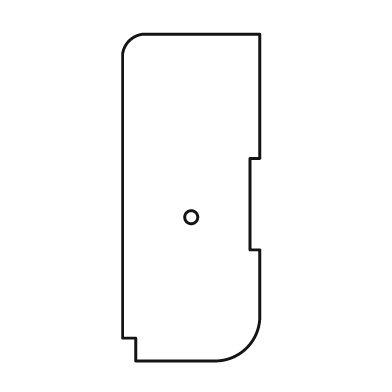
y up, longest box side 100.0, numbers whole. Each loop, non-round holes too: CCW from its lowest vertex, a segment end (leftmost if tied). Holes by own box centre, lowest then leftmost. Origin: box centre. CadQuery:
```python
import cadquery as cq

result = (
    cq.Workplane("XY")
    .moveTo(-17.0, -50.0)
    .lineTo(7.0, -50.0)
    .threePointArc((17.0, -46.0), (21.0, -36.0))
    .lineTo(21.0, -16.0)
    .lineTo(18.0, -16.0)
    .lineTo(18.0, 12.0)
    .lineTo(21.0, 12.0)
    .lineTo(21.0, 50.0)
    .lineTo(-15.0, 50.0)
    .threePointArc((-19.0, 48.0), (-21.0, 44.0))
    .lineTo(-21.0, -43.0)
    .lineTo(-17.0, -43.0)
    .close()
    .moveTo(0.0, -6.0)
    .circle(2.0)
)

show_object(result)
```